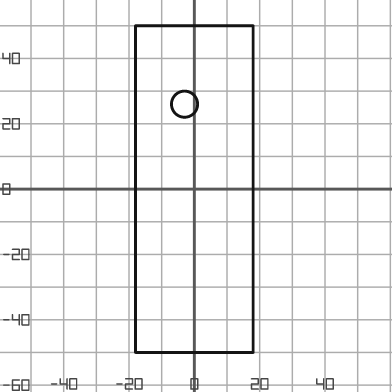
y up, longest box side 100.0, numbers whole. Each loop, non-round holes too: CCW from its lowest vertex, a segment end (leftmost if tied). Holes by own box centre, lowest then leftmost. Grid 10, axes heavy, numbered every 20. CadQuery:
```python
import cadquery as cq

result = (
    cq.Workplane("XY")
    .moveTo(-18.0, -50.0)
    .lineTo(18.0, -50.0)
    .lineTo(18.0, 50.0)
    .lineTo(-18.0, 50.0)
    .close()
    .moveTo(-3.0, 26.0)
    .circle(4.0)
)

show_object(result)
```